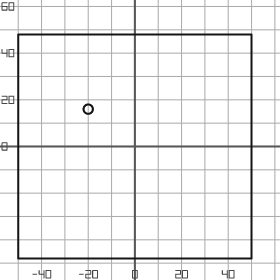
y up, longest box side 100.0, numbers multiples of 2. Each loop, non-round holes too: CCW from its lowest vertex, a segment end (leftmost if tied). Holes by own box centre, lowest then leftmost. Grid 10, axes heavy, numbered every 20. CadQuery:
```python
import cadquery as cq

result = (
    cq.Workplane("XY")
    .moveTo(-50.0, -48.0)
    .lineTo(50.0, -48.0)
    .lineTo(50.0, 48.0)
    .lineTo(-50.0, 48.0)
    .close()
    .moveTo(-20.0, 16.0)
    .circle(2.0)
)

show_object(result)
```